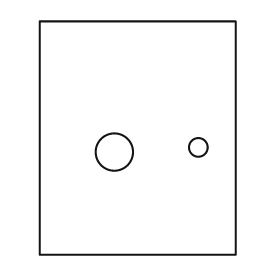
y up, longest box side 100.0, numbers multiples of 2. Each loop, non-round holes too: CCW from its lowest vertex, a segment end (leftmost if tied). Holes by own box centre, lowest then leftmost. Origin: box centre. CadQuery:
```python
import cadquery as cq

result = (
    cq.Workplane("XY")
    .moveTo(-42.0, -50.0)
    .lineTo(42.0, -50.0)
    .lineTo(42.0, 50.0)
    .lineTo(-42.0, 50.0)
    .close()
    .moveTo(-10.0, -6.0)
    .circle(8.0)
    .moveTo(26.0, -4.0)
    .circle(4.0)
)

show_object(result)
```